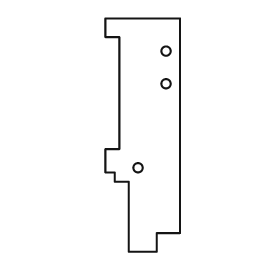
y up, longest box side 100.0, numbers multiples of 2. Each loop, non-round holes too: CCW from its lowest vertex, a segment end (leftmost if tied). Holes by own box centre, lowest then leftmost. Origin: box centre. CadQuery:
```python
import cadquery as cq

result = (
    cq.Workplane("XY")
    .moveTo(-6.0, -50.0)
    .lineTo(6.0, -50.0)
    .lineTo(6.0, -42.0)
    .lineTo(16.0, -42.0)
    .lineTo(16.0, 50.0)
    .lineTo(-16.0, 50.0)
    .lineTo(-16.0, 42.0)
    .lineTo(-10.0, 42.0)
    .lineTo(-10.0, -6.0)
    .lineTo(-16.0, -6.0)
    .lineTo(-16.0, -16.0)
    .lineTo(-12.0, -16.0)
    .lineTo(-12.0, -20.0)
    .lineTo(-6.0, -20.0)
    .close()
    .moveTo(-2.0, -14.0)
    .circle(2.0)
    .moveTo(10.0, 22.0)
    .circle(2.0)
    .moveTo(10.0, 36.0)
    .circle(2.0)
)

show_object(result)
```